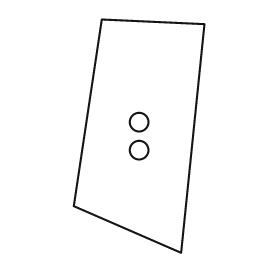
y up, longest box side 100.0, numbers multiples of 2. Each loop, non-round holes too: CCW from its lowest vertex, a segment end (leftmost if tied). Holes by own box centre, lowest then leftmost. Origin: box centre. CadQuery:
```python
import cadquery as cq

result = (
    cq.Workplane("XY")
    .moveTo(18.0, -50.0)
    .lineTo(28.0, 48.0)
    .lineTo(-16.0, 50.0)
    .lineTo(-28.0, -30.0)
    .close()
    .moveTo(0.0, -6.0)
    .circle(4.0)
    .moveTo(0.0, 6.0)
    .circle(4.0)
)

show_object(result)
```